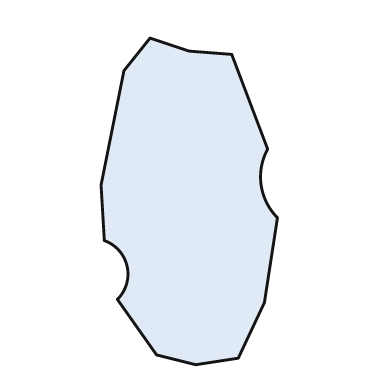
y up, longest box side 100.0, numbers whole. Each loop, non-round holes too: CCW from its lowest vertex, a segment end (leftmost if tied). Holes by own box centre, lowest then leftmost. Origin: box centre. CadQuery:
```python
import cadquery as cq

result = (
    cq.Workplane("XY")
    .moveTo(2.0, -50.0)
    .lineTo(15.0, -48.0)
    .lineTo(23.0, -31.0)
    .lineTo(27.0, -5.0)
    .threePointArc((22.0, 5.0), (24.0, 16.0))
    .lineTo(13.0, 45.0)
    .lineTo(0.0, 46.0)
    .lineTo(-12.0, 50.0)
    .lineTo(-20.0, 40.0)
    .lineTo(-27.0, 5.0)
    .lineTo(-26.0, -12.0)
    .threePointArc((-19.0, -20.0), (-22.0, -30.0))
    .lineTo(-10.0, -47.0)
    .close()
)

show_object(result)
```